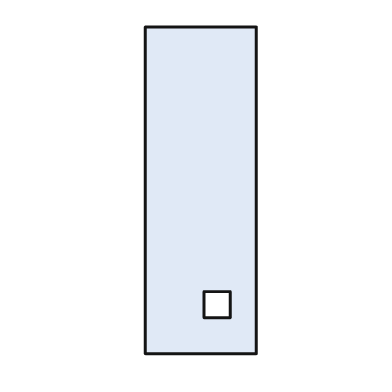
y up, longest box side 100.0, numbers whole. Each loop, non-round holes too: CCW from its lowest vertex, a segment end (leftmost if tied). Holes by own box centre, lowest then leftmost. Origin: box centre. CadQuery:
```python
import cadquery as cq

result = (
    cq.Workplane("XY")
    .moveTo(-17.0, -50.0)
    .lineTo(17.0, -50.0)
    .lineTo(17.0, 50.0)
    .lineTo(-17.0, 50.0)
    .close()
    .moveTo(1.0, -39.0)
    .lineTo(9.0, -39.0)
    .lineTo(9.0, -31.0)
    .lineTo(1.0, -31.0)
    .close()
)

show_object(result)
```